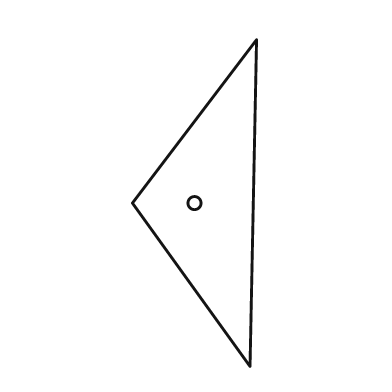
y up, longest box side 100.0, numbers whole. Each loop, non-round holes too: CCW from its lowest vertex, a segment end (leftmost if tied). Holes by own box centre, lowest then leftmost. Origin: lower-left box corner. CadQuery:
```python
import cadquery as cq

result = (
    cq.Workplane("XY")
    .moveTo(36.0, 0.0)
    .lineTo(38.0, 100.0)
    .lineTo(0.0, 50.0)
    .close()
    .moveTo(19.0, 50.0)
    .circle(2.0)
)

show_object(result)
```